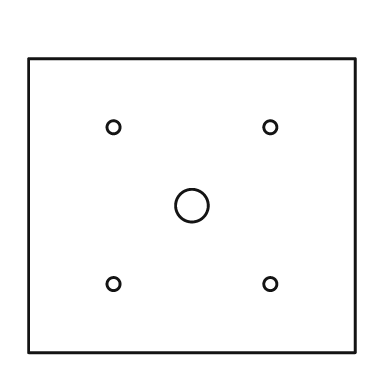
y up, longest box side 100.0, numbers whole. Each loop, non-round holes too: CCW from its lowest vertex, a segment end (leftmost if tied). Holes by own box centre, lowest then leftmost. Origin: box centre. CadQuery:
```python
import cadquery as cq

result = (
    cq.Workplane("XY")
    .moveTo(-50.0, -45.0)
    .lineTo(50.0, -45.0)
    .lineTo(50.0, 45.0)
    .lineTo(-50.0, 45.0)
    .close()
    .moveTo(-24.0, -24.0)
    .circle(2.0)
    .moveTo(24.0, -24.0)
    .circle(2.0)
    .moveTo(0.0, 0.0)
    .circle(5.0)
    .moveTo(-24.0, 24.0)
    .circle(2.0)
    .moveTo(24.0, 24.0)
    .circle(2.0)
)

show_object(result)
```